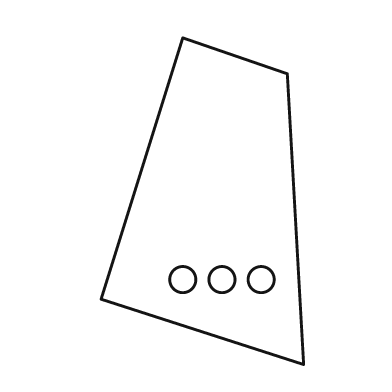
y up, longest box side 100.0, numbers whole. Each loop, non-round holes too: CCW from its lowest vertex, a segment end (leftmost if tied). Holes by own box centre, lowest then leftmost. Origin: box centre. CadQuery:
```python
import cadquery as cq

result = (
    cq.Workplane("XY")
    .moveTo(31.0, -50.0)
    .lineTo(26.0, 39.0)
    .lineTo(-6.0, 50.0)
    .lineTo(-31.0, -30.0)
    .close()
    .moveTo(-6.0, -24.0)
    .circle(4.0)
    .moveTo(6.0, -24.0)
    .circle(4.0)
    .moveTo(18.0, -24.0)
    .circle(4.0)
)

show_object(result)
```